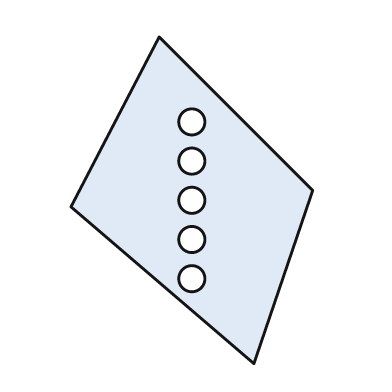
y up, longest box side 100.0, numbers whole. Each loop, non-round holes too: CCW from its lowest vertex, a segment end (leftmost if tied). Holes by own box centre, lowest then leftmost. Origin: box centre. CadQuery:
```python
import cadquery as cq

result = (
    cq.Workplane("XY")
    .moveTo(19.0, -50.0)
    .lineTo(37.0, 3.0)
    .lineTo(-10.0, 50.0)
    .lineTo(-37.0, -2.0)
    .close()
    .moveTo(0.0, -24.0)
    .circle(4.0)
    .moveTo(0.0, -12.0)
    .circle(4.0)
    .moveTo(0.0, 0.0)
    .circle(4.0)
    .moveTo(0.0, 12.0)
    .circle(4.0)
    .moveTo(0.0, 24.0)
    .circle(4.0)
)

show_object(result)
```